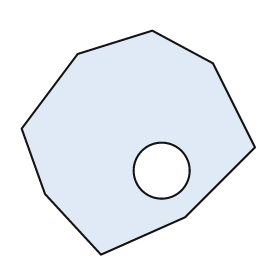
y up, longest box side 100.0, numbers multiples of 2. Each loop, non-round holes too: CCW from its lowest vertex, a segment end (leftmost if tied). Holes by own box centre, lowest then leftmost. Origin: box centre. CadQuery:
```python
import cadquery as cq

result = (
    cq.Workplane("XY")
    .moveTo(-16.0, -48.0)
    .lineTo(20.0, -32.0)
    .lineTo(50.0, -2.0)
    .lineTo(32.0, 34.0)
    .lineTo(6.0, 48.0)
    .lineTo(-26.0, 38.0)
    .lineTo(-50.0, 6.0)
    .lineTo(-40.0, -22.0)
    .close()
    .moveTo(10.0, -12.0)
    .circle(12.0)
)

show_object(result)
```